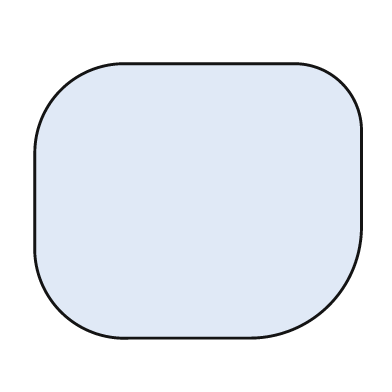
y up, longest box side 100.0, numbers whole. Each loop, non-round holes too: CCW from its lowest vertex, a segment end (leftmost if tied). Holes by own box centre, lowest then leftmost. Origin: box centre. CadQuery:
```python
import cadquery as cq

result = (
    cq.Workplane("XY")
    .moveTo(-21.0, -42.0)
    .lineTo(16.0, -42.0)
    .threePointArc((40.0, -32.0), (50.0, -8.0))
    .lineTo(50.0, 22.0)
    .threePointArc((44.0, 36.0), (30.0, 42.0))
    .lineTo(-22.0, 42.0)
    .threePointArc((-42.0, 34.0), (-50.0, 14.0))
    .lineTo(-50.0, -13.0)
    .threePointArc((-42.0, -34.0), (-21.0, -42.0))
    .close()
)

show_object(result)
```